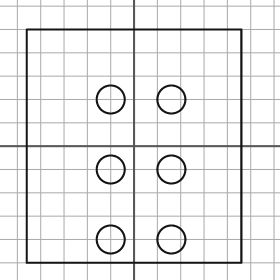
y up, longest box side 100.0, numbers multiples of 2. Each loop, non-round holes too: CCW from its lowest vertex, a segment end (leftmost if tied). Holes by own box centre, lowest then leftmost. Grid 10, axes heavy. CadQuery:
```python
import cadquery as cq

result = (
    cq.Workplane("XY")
    .moveTo(-46.0, -50.0)
    .lineTo(46.0, -50.0)
    .lineTo(46.0, 50.0)
    .lineTo(-46.0, 50.0)
    .close()
    .moveTo(-10.0, -40.0)
    .circle(6.0)
    .moveTo(16.0, -40.0)
    .circle(6.0)
    .moveTo(-10.0, -10.0)
    .circle(6.0)
    .moveTo(16.0, -10.0)
    .circle(6.0)
    .moveTo(-10.0, 20.0)
    .circle(6.0)
    .moveTo(16.0, 20.0)
    .circle(6.0)
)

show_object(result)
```